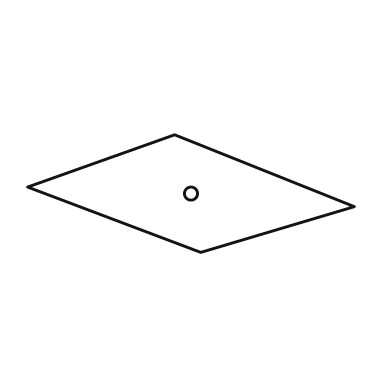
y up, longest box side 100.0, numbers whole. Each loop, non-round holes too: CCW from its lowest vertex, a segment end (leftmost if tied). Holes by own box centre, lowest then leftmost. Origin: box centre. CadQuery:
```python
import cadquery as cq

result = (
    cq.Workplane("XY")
    .moveTo(3.0, -18.0)
    .lineTo(50.0, -4.0)
    .lineTo(-5.0, 18.0)
    .lineTo(-50.0, 2.0)
    .close()
    .moveTo(0.0, 0.0)
    .circle(2.0)
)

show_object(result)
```